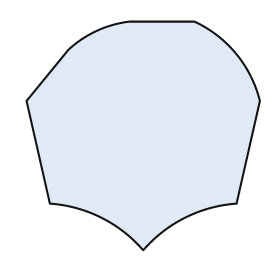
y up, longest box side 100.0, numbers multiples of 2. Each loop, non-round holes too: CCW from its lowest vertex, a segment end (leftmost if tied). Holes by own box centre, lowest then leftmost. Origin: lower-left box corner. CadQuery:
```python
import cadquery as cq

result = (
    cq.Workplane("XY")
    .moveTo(50.0, 0.0)
    .threePointArc((68.0, 14.0), (90.0, 20.0))
    .lineTo(100.0, 64.0)
    .threePointArc((90.0, 84.0), (72.0, 98.0))
    .lineTo(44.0, 98.0)
    .threePointArc((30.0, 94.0), (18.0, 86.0))
    .lineTo(0.0, 64.0)
    .lineTo(10.0, 20.0)
    .threePointArc((32.0, 14.0), (50.0, 0.0))
    .close()
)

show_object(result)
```